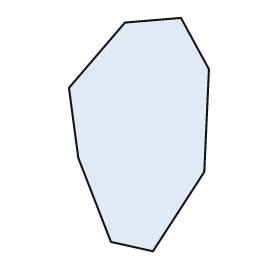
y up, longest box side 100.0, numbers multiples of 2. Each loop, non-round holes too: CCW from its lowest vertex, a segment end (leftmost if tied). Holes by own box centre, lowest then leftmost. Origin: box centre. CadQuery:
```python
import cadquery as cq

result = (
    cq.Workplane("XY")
    .moveTo(6.0, -50.0)
    .lineTo(28.0, -16.0)
    .lineTo(30.0, 28.0)
    .lineTo(18.0, 50.0)
    .lineTo(-6.0, 48.0)
    .lineTo(-30.0, 20.0)
    .lineTo(-26.0, -10.0)
    .lineTo(-12.0, -46.0)
    .close()
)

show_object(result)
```